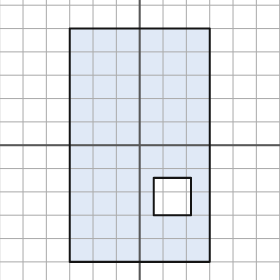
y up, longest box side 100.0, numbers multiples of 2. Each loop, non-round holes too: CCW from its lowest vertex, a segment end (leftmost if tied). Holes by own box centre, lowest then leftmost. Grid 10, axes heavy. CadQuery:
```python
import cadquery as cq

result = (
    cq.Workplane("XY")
    .moveTo(-30.0, -50.0)
    .lineTo(30.0, -50.0)
    .lineTo(30.0, 50.0)
    .lineTo(-30.0, 50.0)
    .close()
    .moveTo(6.0, -30.0)
    .lineTo(22.0, -30.0)
    .lineTo(22.0, -14.0)
    .lineTo(6.0, -14.0)
    .close()
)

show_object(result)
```